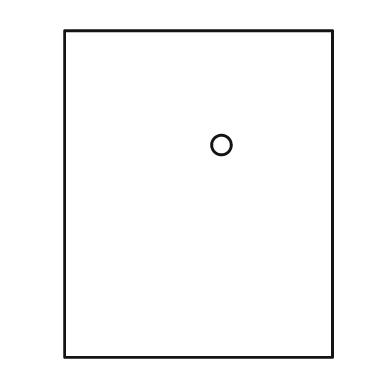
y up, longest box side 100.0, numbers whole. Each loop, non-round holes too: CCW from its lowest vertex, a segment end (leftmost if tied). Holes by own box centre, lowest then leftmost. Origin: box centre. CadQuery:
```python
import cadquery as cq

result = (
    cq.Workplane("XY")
    .moveTo(-41.0, -50.0)
    .lineTo(41.0, -50.0)
    .lineTo(41.0, 50.0)
    .lineTo(-41.0, 50.0)
    .close()
    .moveTo(7.0, 15.0)
    .circle(3.0)
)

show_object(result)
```